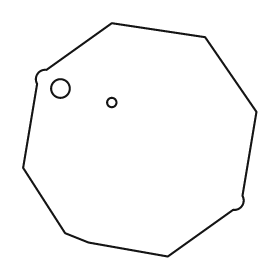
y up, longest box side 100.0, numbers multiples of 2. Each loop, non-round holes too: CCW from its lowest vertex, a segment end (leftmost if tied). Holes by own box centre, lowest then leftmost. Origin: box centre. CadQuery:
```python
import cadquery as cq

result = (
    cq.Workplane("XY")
    .moveTo(12.0, -50.0)
    .lineTo(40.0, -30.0)
    .threePointArc((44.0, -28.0), (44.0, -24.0))
    .lineTo(50.0, 12.0)
    .lineTo(28.0, 44.0)
    .lineTo(-12.0, 50.0)
    .lineTo(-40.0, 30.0)
    .threePointArc((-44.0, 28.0), (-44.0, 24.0))
    .lineTo(-50.0, -12.0)
    .lineTo(-32.0, -40.0)
    .lineTo(-22.0, -44.0)
    .close()
    .moveTo(-12.0, 16.0)
    .circle(2.0)
    .moveTo(-34.0, 22.0)
    .circle(4.0)
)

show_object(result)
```